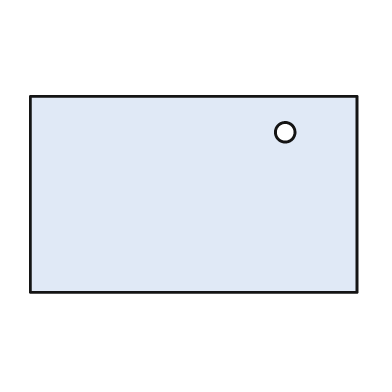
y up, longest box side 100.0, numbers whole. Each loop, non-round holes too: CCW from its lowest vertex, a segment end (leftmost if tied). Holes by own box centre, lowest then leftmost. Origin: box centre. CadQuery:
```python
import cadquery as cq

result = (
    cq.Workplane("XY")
    .moveTo(-50.0, -30.0)
    .lineTo(50.0, -30.0)
    .lineTo(50.0, 30.0)
    .lineTo(-50.0, 30.0)
    .close()
    .moveTo(28.0, 19.0)
    .circle(3.0)
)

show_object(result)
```